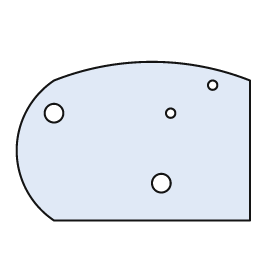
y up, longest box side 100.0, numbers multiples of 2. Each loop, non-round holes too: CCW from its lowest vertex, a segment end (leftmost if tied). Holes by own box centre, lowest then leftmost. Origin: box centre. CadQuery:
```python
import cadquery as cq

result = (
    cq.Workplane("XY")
    .moveTo(-34.0, -34.0)
    .lineTo(50.0, -34.0)
    .lineTo(50.0, 26.0)
    .threePointArc((8.0, 34.0), (-34.0, 26.0))
    .threePointArc((-50.0, -4.0), (-34.0, -34.0))
    .close()
    .moveTo(12.0, -18.0)
    .circle(4.0)
    .moveTo(-34.0, 12.0)
    .circle(4.0)
    .moveTo(16.0, 12.0)
    .circle(2.0)
    .moveTo(34.0, 24.0)
    .circle(2.0)
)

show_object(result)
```